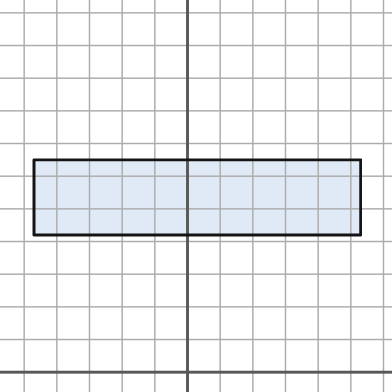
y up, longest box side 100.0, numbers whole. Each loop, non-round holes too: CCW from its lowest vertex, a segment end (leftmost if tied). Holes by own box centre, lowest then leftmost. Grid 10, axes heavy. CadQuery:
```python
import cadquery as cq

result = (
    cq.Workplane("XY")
    .moveTo(-47.0, 42.0)
    .lineTo(53.0, 42.0)
    .lineTo(53.0, 65.0)
    .lineTo(-47.0, 65.0)
    .close()
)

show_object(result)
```